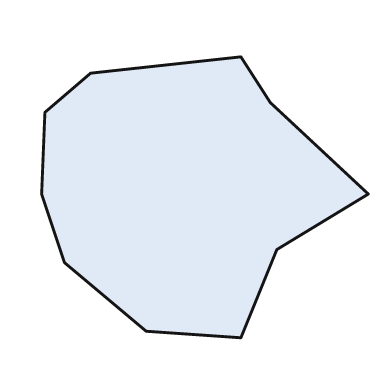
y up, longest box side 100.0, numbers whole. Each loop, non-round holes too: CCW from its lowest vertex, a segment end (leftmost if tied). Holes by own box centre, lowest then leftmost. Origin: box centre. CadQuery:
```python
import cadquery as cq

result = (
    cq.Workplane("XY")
    .moveTo(11.0, -43.0)
    .lineTo(22.0, -16.0)
    .lineTo(50.0, 1.0)
    .lineTo(20.0, 29.0)
    .lineTo(11.0, 43.0)
    .lineTo(-35.0, 38.0)
    .lineTo(-49.0, 26.0)
    .lineTo(-50.0, 1.0)
    .lineTo(-43.0, -20.0)
    .lineTo(-18.0, -41.0)
    .close()
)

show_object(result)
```